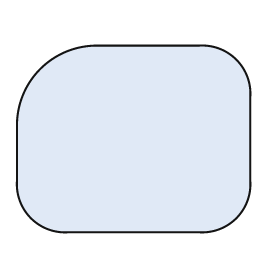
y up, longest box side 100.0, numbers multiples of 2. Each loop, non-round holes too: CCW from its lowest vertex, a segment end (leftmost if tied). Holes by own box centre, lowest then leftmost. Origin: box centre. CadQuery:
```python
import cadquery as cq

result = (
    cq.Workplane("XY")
    .moveTo(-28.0, -40.0)
    .lineTo(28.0, -40.0)
    .threePointArc((44.0, -34.0), (50.0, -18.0))
    .lineTo(50.0, 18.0)
    .threePointArc((44.0, 34.0), (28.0, 40.0))
    .lineTo(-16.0, 40.0)
    .threePointArc((-40.0, 30.0), (-50.0, 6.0))
    .lineTo(-50.0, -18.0)
    .threePointArc((-44.0, -34.0), (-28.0, -40.0))
    .close()
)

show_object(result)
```